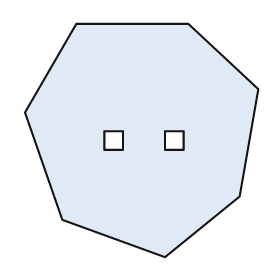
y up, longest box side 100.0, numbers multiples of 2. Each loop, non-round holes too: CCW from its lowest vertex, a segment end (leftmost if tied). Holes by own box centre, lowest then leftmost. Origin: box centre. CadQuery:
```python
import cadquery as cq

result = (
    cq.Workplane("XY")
    .moveTo(10.0, -50.0)
    .lineTo(42.0, -24.0)
    .lineTo(50.0, 22.0)
    .lineTo(20.0, 50.0)
    .lineTo(-28.0, 50.0)
    .lineTo(-50.0, 12.0)
    .lineTo(-34.0, -34.0)
    .close()
    .moveTo(-16.0, -4.0)
    .lineTo(-8.0, -4.0)
    .lineTo(-8.0, 4.0)
    .lineTo(-16.0, 4.0)
    .close()
    .moveTo(10.0, -4.0)
    .lineTo(18.0, -4.0)
    .lineTo(18.0, 4.0)
    .lineTo(10.0, 4.0)
    .close()
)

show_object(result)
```